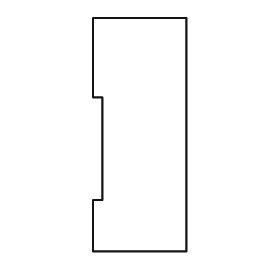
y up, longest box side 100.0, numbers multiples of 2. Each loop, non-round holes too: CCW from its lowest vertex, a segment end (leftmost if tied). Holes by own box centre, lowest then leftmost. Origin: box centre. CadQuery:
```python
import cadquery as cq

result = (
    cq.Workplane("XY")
    .moveTo(-20.0, -50.0)
    .lineTo(20.0, -50.0)
    .lineTo(20.0, 50.0)
    .lineTo(-20.0, 50.0)
    .lineTo(-20.0, 16.0)
    .lineTo(-16.0, 16.0)
    .lineTo(-16.0, -28.0)
    .lineTo(-20.0, -28.0)
    .close()
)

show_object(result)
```